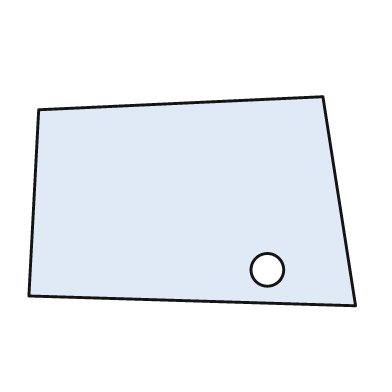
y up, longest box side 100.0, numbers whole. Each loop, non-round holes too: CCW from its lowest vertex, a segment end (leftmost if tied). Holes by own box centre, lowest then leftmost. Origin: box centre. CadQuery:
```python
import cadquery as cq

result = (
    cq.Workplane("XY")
    .moveTo(50.0, -32.0)
    .lineTo(40.0, 32.0)
    .lineTo(-47.0, 28.0)
    .lineTo(-50.0, -29.0)
    .close()
    .moveTo(23.0, -21.0)
    .circle(5.0)
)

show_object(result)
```